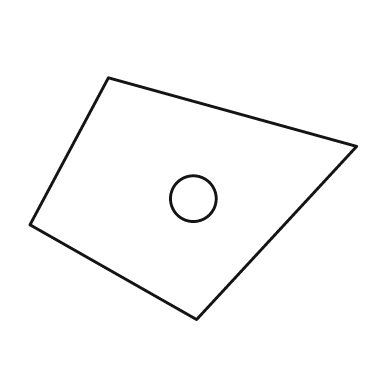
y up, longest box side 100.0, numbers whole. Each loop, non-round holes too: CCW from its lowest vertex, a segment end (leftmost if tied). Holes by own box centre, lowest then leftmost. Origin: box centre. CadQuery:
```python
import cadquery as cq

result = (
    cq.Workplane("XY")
    .moveTo(1.0, -37.0)
    .lineTo(50.0, 16.0)
    .lineTo(-26.0, 37.0)
    .lineTo(-50.0, -8.0)
    .close()
    .moveTo(0.0, 0.0)
    .circle(7.0)
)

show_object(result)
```